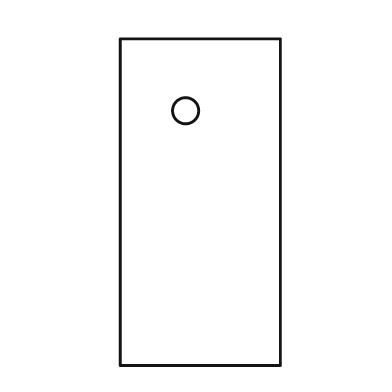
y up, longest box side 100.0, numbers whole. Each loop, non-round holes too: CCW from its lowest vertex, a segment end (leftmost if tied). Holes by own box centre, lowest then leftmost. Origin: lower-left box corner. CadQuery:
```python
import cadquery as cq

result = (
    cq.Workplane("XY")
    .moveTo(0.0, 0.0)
    .lineTo(49.0, 0.0)
    .lineTo(49.0, 100.0)
    .lineTo(0.0, 100.0)
    .close()
    .moveTo(20.0, 78.0)
    .circle(4.0)
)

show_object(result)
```